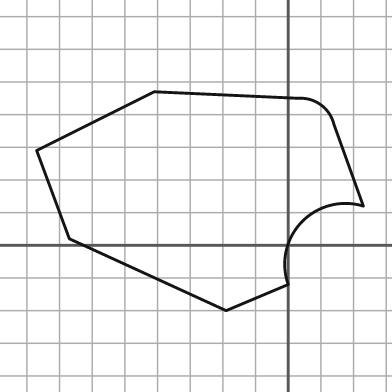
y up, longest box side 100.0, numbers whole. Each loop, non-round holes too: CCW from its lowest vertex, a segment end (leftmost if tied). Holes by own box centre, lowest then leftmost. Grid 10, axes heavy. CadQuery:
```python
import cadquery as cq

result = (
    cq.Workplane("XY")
    .moveTo(-19.0, -20.0)
    .lineTo(0.0, -12.0)
    .threePointArc((4.0, 7.0), (23.0, 12.0))
    .lineTo(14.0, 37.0)
    .threePointArc((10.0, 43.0), (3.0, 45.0))
    .lineTo(-41.0, 47.0)
    .lineTo(-77.0, 29.0)
    .lineTo(-67.0, 2.0)
    .close()
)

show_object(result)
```